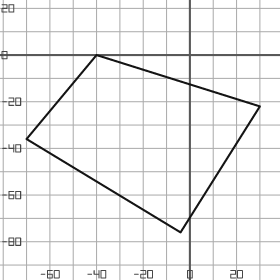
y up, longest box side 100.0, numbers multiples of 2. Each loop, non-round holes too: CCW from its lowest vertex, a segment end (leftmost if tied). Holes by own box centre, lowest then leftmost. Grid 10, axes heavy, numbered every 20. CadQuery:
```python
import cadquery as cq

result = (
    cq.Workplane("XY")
    .moveTo(-4.0, -76.0)
    .lineTo(30.0, -22.0)
    .lineTo(-40.0, 0.0)
    .lineTo(-70.0, -36.0)
    .close()
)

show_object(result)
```